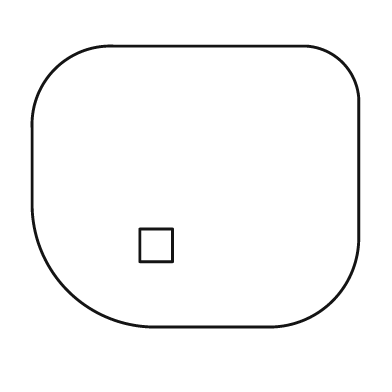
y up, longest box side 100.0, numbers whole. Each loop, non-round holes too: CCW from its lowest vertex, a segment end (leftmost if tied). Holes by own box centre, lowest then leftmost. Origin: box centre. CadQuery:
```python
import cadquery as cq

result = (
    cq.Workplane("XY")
    .moveTo(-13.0, -43.0)
    .lineTo(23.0, -43.0)
    .threePointArc((42.0, -35.0), (50.0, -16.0))
    .lineTo(50.0, 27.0)
    .threePointArc((45.0, 38.0), (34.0, 43.0))
    .lineTo(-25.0, 43.0)
    .threePointArc((-43.0, 36.0), (-50.0, 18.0))
    .lineTo(-50.0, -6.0)
    .threePointArc((-39.0, -32.0), (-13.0, -43.0))
    .close()
    .moveTo(-17.0, -23.0)
    .lineTo(-7.0, -23.0)
    .lineTo(-7.0, -13.0)
    .lineTo(-17.0, -13.0)
    .close()
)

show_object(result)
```